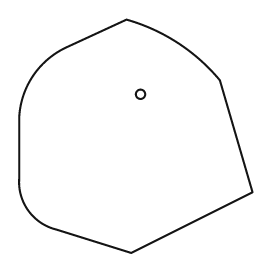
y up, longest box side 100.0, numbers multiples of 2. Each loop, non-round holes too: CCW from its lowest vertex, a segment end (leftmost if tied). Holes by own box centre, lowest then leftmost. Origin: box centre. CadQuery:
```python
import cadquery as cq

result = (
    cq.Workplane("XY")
    .moveTo(-2.0, -50.0)
    .lineTo(50.0, -24.0)
    .lineTo(36.0, 24.0)
    .threePointArc((18.0, 40.0), (-4.0, 50.0))
    .lineTo(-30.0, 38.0)
    .threePointArc((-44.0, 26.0), (-50.0, 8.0))
    .lineTo(-50.0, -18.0)
    .threePointArc((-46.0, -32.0), (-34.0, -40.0))
    .close()
    .moveTo(2.0, 18.0)
    .circle(2.0)
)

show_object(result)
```